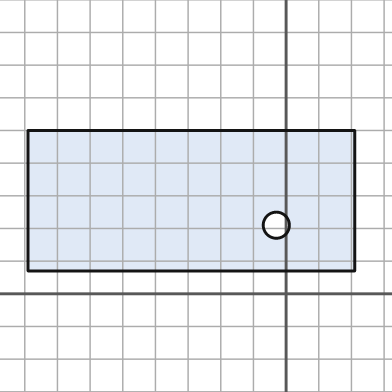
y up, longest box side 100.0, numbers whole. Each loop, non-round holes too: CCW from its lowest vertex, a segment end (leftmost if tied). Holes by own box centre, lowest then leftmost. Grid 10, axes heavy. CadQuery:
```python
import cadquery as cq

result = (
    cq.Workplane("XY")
    .moveTo(-79.0, 7.0)
    .lineTo(21.0, 7.0)
    .lineTo(21.0, 50.0)
    .lineTo(-79.0, 50.0)
    .close()
    .moveTo(-3.0, 21.0)
    .circle(4.0)
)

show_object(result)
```